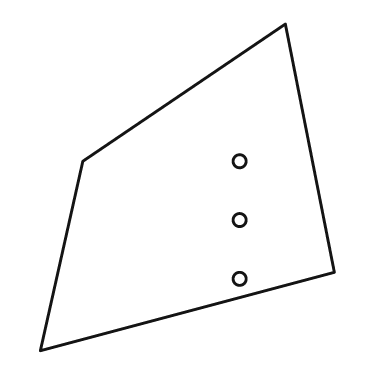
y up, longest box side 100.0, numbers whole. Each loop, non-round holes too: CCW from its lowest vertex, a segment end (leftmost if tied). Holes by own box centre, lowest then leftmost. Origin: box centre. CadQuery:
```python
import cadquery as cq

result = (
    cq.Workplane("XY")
    .moveTo(-45.0, -50.0)
    .lineTo(45.0, -26.0)
    .lineTo(30.0, 50.0)
    .lineTo(-32.0, 8.0)
    .close()
    .moveTo(16.0, -28.0)
    .circle(2.0)
    .moveTo(16.0, -10.0)
    .circle(2.0)
    .moveTo(16.0, 8.0)
    .circle(2.0)
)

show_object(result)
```